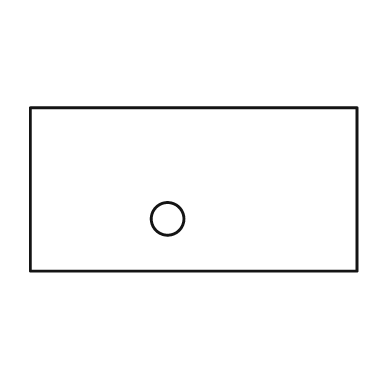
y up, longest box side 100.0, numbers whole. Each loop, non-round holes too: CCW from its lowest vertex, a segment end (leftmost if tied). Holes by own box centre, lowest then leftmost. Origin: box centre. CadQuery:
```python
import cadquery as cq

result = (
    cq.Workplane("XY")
    .moveTo(-50.0, -25.0)
    .lineTo(50.0, -25.0)
    .lineTo(50.0, 25.0)
    .lineTo(-50.0, 25.0)
    .close()
    .moveTo(-8.0, -9.0)
    .circle(5.0)
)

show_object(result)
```